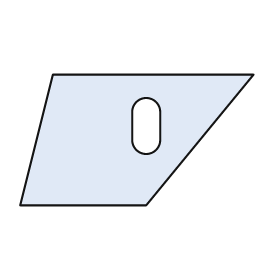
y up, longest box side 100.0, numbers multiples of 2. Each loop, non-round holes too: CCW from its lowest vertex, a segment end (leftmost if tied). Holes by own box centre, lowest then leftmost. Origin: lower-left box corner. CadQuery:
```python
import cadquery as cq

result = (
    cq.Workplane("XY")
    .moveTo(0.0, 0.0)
    .lineTo(54.0, 0.0)
    .lineTo(100.0, 56.0)
    .lineTo(14.0, 56.0)
    .close()
    .moveTo(48.0, 28.0)
    .threePointArc((54.0, 22.0), (60.0, 28.0))
    .lineTo(60.0, 40.0)
    .threePointArc((54.0, 46.0), (48.0, 40.0))
    .close()
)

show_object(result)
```